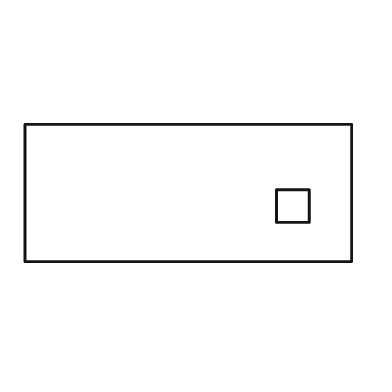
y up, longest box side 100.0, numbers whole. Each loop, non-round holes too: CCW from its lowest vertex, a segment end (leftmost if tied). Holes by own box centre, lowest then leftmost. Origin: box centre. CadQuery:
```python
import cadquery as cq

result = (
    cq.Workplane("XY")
    .moveTo(-50.0, -21.0)
    .lineTo(50.0, -21.0)
    .lineTo(50.0, 21.0)
    .lineTo(-50.0, 21.0)
    .close()
    .moveTo(27.0, -9.0)
    .lineTo(37.0, -9.0)
    .lineTo(37.0, 1.0)
    .lineTo(27.0, 1.0)
    .close()
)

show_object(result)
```